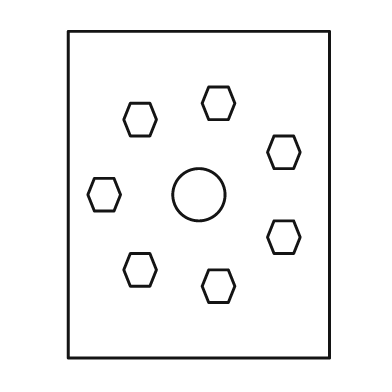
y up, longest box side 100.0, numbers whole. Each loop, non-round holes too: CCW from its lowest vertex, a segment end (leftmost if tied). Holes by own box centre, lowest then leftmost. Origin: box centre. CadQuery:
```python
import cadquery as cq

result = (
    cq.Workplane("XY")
    .moveTo(-40.0, -50.0)
    .lineTo(40.0, -50.0)
    .lineTo(40.0, 50.0)
    .lineTo(-40.0, 50.0)
    .close()
    .moveTo(3.0, -33.0)
    .lineTo(9.0, -33.0)
    .lineTo(11.0, -28.0)
    .lineTo(9.0, -23.0)
    .lineTo(3.0, -23.0)
    .lineTo(1.0, -28.0)
    .close()
    .moveTo(-21.0, -28.0)
    .lineTo(-15.0, -28.0)
    .lineTo(-13.0, -23.0)
    .lineTo(-15.0, -18.0)
    .lineTo(-21.0, -18.0)
    .lineTo(-23.0, -23.0)
    .close()
    .moveTo(23.0, -18.0)
    .lineTo(29.0, -18.0)
    .lineTo(31.0, -13.0)
    .lineTo(29.0, -8.0)
    .lineTo(23.0, -8.0)
    .lineTo(21.0, -13.0)
    .close()
    .moveTo(-32.0, -5.0)
    .lineTo(-26.0, -5.0)
    .lineTo(-24.0, 0.0)
    .lineTo(-26.0, 5.0)
    .lineTo(-32.0, 5.0)
    .lineTo(-34.0, 0.0)
    .close()
    .moveTo(0.0, 0.0)
    .circle(8.0)
    .moveTo(23.0, 8.0)
    .lineTo(29.0, 8.0)
    .lineTo(31.0, 13.0)
    .lineTo(29.0, 18.0)
    .lineTo(23.0, 18.0)
    .lineTo(21.0, 13.0)
    .close()
    .moveTo(-21.0, 18.0)
    .lineTo(-15.0, 18.0)
    .lineTo(-13.0, 23.0)
    .lineTo(-15.0, 28.0)
    .lineTo(-21.0, 28.0)
    .lineTo(-23.0, 23.0)
    .close()
    .moveTo(3.0, 23.0)
    .lineTo(9.0, 23.0)
    .lineTo(11.0, 28.0)
    .lineTo(9.0, 33.0)
    .lineTo(3.0, 33.0)
    .lineTo(1.0, 28.0)
    .close()
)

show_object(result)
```